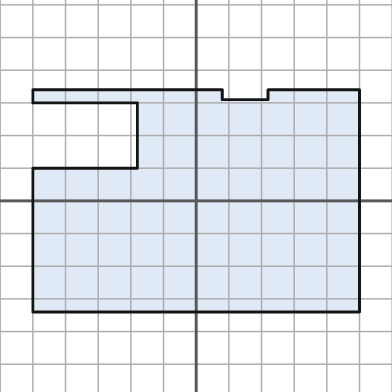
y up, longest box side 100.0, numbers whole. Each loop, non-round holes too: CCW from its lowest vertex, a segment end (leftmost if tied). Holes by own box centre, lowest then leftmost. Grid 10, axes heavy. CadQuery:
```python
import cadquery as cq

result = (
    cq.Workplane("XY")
    .moveTo(-50.0, -34.0)
    .lineTo(50.0, -34.0)
    .lineTo(50.0, 34.0)
    .lineTo(22.0, 34.0)
    .lineTo(22.0, 31.0)
    .lineTo(8.0, 31.0)
    .lineTo(8.0, 34.0)
    .lineTo(-50.0, 34.0)
    .lineTo(-50.0, 30.0)
    .lineTo(-18.0, 30.0)
    .lineTo(-18.0, 10.0)
    .lineTo(-50.0, 10.0)
    .close()
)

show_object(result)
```